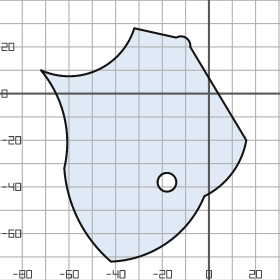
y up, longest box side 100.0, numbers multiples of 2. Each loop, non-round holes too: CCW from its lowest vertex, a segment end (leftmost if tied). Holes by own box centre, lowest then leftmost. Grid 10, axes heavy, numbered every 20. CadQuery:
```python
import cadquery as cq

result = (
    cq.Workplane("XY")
    .moveTo(-42.0, -72.0)
    .threePointArc((-18.0, -64.0), (-2.0, -44.0))
    .threePointArc((10.0, -34.0), (16.0, -20.0))
    .lineTo(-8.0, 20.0)
    .threePointArc((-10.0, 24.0), (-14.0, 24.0))
    .lineTo(-32.0, 28.0)
    .threePointArc((-48.0, 10.0), (-72.0, 10.0))
    .threePointArc((-62.0, -10.0), (-62.0, -32.0))
    .threePointArc((-56.0, -54.0), (-42.0, -72.0))
    .close()
    .moveTo(-18.0, -38.0)
    .circle(4.0)
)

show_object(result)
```